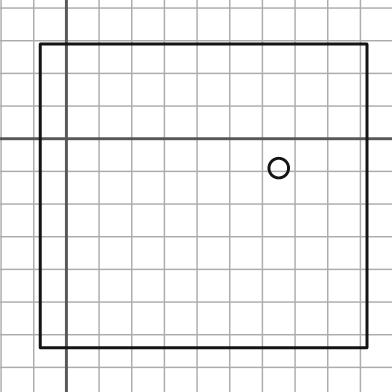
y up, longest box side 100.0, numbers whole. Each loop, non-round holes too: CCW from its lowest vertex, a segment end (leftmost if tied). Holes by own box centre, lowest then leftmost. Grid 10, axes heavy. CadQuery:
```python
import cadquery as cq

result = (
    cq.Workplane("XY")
    .moveTo(-8.0, -64.0)
    .lineTo(92.0, -64.0)
    .lineTo(92.0, 29.0)
    .lineTo(-8.0, 29.0)
    .close()
    .moveTo(65.0, -9.0)
    .circle(3.0)
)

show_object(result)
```